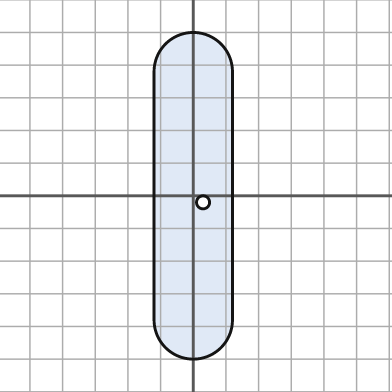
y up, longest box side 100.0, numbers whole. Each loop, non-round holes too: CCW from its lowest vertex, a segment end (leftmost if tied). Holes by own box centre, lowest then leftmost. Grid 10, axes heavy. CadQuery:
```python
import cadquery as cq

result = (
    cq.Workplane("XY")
    .moveTo(-12.0, -38.0)
    .threePointArc((0.0, -50.0), (12.0, -38.0))
    .lineTo(12.0, 38.0)
    .threePointArc((0.0, 50.0), (-12.0, 38.0))
    .close()
    .moveTo(3.0, -2.0)
    .circle(2.0)
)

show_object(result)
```